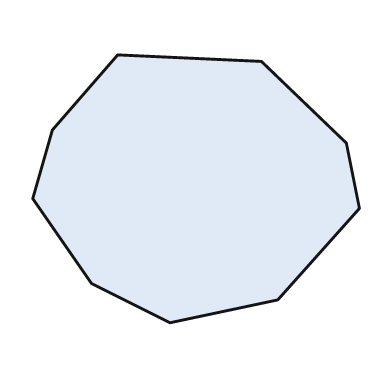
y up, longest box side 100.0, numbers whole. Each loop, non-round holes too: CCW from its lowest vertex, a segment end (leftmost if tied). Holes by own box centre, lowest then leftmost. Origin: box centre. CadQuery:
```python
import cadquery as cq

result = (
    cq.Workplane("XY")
    .moveTo(-8.0, -41.0)
    .lineTo(25.0, -34.0)
    .lineTo(50.0, -6.0)
    .lineTo(46.0, 14.0)
    .lineTo(20.0, 39.0)
    .lineTo(-24.0, 41.0)
    .lineTo(-44.0, 18.0)
    .lineTo(-50.0, -3.0)
    .lineTo(-32.0, -29.0)
    .close()
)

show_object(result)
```